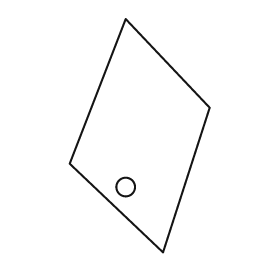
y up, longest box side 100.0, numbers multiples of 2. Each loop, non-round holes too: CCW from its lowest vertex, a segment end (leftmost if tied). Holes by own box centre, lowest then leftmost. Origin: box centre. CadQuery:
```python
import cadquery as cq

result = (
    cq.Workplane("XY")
    .moveTo(10.0, -50.0)
    .lineTo(30.0, 12.0)
    .lineTo(-6.0, 50.0)
    .lineTo(-30.0, -12.0)
    .close()
    .moveTo(-6.0, -22.0)
    .circle(4.0)
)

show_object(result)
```